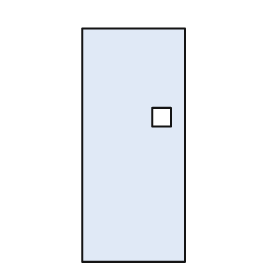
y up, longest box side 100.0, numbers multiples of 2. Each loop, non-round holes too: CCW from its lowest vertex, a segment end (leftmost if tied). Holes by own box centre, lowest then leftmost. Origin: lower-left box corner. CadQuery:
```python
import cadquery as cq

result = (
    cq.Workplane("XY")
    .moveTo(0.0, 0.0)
    .lineTo(44.0, 0.0)
    .lineTo(44.0, 100.0)
    .lineTo(0.0, 100.0)
    .close()
    .moveTo(30.0, 58.0)
    .lineTo(38.0, 58.0)
    .lineTo(38.0, 66.0)
    .lineTo(30.0, 66.0)
    .close()
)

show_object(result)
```